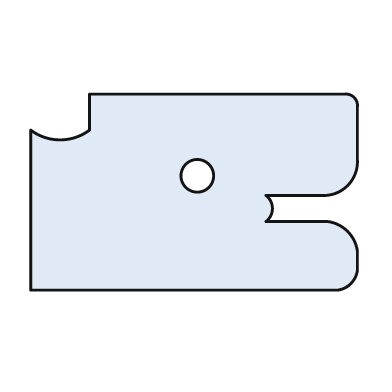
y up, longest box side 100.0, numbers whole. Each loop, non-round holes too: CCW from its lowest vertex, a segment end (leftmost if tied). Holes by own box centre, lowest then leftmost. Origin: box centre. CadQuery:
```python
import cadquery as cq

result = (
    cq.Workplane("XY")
    .moveTo(-50.0, -30.0)
    .lineTo(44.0, -30.0)
    .threePointArc((48.0, -28.0), (50.0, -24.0))
    .lineTo(50.0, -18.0)
    .threePointArc((47.0, -12.0), (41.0, -9.0))
    .lineTo(22.0, -9.0)
    .threePointArc((24.0, -5.0), (22.0, -1.0))
    .lineTo(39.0, -1.0)
    .threePointArc((47.0, 2.0), (50.0, 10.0))
    .lineTo(50.0, 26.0)
    .threePointArc((49.0, 29.0), (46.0, 30.0))
    .lineTo(-32.0, 30.0)
    .lineTo(-32.0, 19.0)
    .threePointArc((-41.0, 16.0), (-50.0, 19.0))
    .close()
    .moveTo(1.0, 5.0)
    .circle(5.0)
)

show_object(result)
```